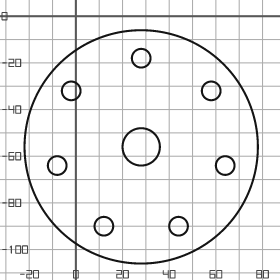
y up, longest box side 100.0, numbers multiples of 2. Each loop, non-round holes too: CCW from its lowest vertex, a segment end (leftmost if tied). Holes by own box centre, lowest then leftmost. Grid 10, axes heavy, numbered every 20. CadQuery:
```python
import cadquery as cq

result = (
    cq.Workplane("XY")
    .moveTo(28.0, -56.0)
    .circle(50.0)
    .moveTo(12.0, -90.0)
    .circle(4.0)
    .moveTo(44.0, -90.0)
    .circle(4.0)
    .moveTo(-8.0, -64.0)
    .circle(4.0)
    .moveTo(64.0, -64.0)
    .circle(4.0)
    .moveTo(28.0, -56.0)
    .circle(8.0)
    .moveTo(-2.0, -32.0)
    .circle(4.0)
    .moveTo(58.0, -32.0)
    .circle(4.0)
    .moveTo(28.0, -18.0)
    .circle(4.0)
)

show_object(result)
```